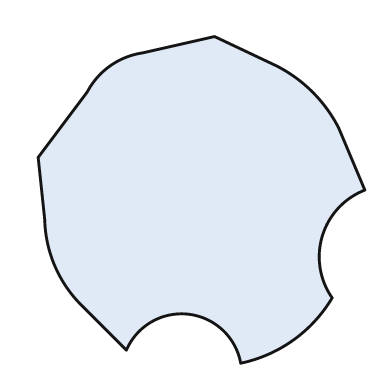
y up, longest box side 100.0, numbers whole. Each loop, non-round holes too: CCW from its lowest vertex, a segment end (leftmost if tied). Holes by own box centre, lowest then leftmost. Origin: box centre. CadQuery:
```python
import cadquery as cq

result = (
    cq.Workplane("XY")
    .moveTo(12.0, -50.0)
    .threePointArc((28.0, -43.0), (40.0, -30.0))
    .threePointArc((37.0, -11.0), (50.0, 3.0))
    .lineTo(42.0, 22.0)
    .threePointArc((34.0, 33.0), (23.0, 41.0))
    .lineTo(4.0, 50.0)
    .lineTo(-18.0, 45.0)
    .threePointArc((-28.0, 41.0), (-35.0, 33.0))
    .lineTo(-50.0, 13.0)
    .lineTo(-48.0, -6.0)
    .threePointArc((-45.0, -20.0), (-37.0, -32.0))
    .lineTo(-23.0, -46.0)
    .threePointArc((-4.0, -35.0), (12.0, -50.0))
    .close()
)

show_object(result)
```